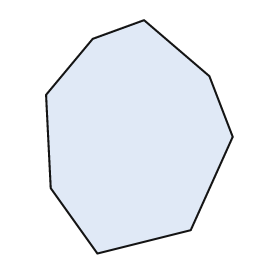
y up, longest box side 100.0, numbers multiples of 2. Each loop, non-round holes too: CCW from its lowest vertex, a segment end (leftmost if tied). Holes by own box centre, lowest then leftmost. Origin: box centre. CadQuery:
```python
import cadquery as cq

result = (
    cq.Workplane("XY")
    .moveTo(-18.0, -50.0)
    .lineTo(22.0, -40.0)
    .lineTo(40.0, 0.0)
    .lineTo(30.0, 26.0)
    .lineTo(2.0, 50.0)
    .lineTo(-20.0, 42.0)
    .lineTo(-40.0, 18.0)
    .lineTo(-38.0, -22.0)
    .close()
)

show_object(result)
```